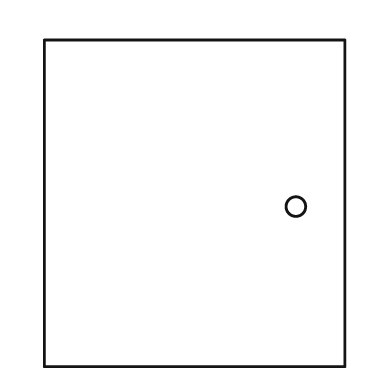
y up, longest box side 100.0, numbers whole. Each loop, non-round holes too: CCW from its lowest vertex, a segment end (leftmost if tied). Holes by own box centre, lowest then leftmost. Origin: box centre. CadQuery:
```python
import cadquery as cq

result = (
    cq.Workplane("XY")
    .moveTo(-46.0, -50.0)
    .lineTo(46.0, -50.0)
    .lineTo(46.0, 50.0)
    .lineTo(-46.0, 50.0)
    .close()
    .moveTo(31.0, -1.0)
    .circle(3.0)
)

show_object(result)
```